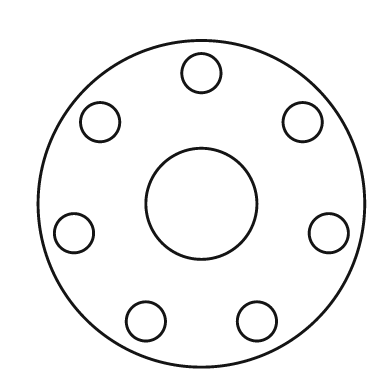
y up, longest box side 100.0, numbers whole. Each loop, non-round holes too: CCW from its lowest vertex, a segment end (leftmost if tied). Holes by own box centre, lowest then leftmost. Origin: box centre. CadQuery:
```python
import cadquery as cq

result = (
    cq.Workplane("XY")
    .moveTo(0.0, 0.0)
    .circle(50.0)
    .moveTo(-17.0, -36.0)
    .circle(6.0)
    .moveTo(17.0, -36.0)
    .circle(6.0)
    .moveTo(-39.0, -9.0)
    .circle(6.0)
    .moveTo(39.0, -9.0)
    .circle(6.0)
    .moveTo(0.0, 0.0)
    .circle(17.0)
    .moveTo(-31.0, 25.0)
    .circle(6.0)
    .moveTo(31.0, 25.0)
    .circle(6.0)
    .moveTo(0.0, 40.0)
    .circle(6.0)
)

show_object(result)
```